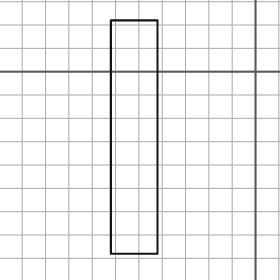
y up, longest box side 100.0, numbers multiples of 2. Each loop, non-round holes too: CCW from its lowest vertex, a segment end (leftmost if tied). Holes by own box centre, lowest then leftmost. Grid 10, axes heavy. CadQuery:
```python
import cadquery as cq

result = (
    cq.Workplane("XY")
    .moveTo(-62.0, -78.0)
    .lineTo(-42.0, -78.0)
    .lineTo(-42.0, 22.0)
    .lineTo(-62.0, 22.0)
    .close()
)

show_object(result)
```